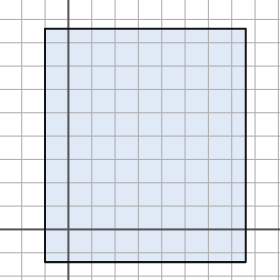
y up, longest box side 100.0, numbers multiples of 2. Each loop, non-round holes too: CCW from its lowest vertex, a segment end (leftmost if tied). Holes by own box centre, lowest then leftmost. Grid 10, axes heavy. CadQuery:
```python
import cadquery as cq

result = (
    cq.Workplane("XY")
    .moveTo(-10.0, -14.0)
    .lineTo(76.0, -14.0)
    .lineTo(76.0, 86.0)
    .lineTo(-10.0, 86.0)
    .close()
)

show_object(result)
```